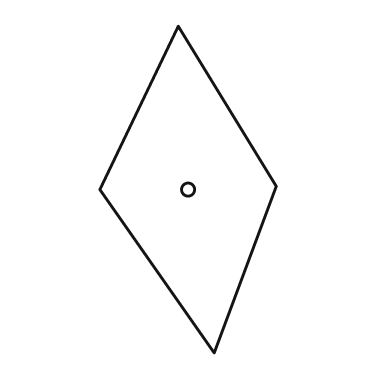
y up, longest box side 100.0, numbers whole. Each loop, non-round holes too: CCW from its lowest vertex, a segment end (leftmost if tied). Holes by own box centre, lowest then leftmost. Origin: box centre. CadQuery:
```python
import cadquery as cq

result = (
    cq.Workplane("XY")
    .moveTo(8.0, -50.0)
    .lineTo(27.0, 1.0)
    .lineTo(-3.0, 50.0)
    .lineTo(-27.0, 0.0)
    .close()
    .moveTo(0.0, 0.0)
    .circle(2.0)
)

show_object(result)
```